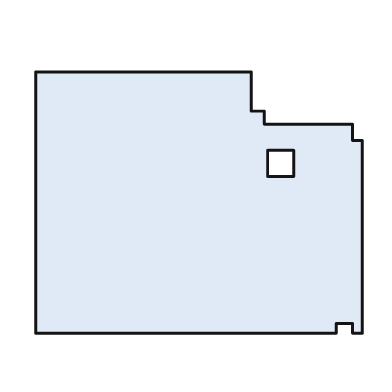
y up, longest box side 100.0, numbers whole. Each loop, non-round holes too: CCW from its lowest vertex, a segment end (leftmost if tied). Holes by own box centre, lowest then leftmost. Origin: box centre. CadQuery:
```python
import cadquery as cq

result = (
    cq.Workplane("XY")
    .moveTo(-50.0, -40.0)
    .lineTo(42.0, -40.0)
    .lineTo(42.0, -37.0)
    .lineTo(47.0, -37.0)
    .lineTo(47.0, -40.0)
    .lineTo(50.0, -40.0)
    .lineTo(50.0, 19.0)
    .lineTo(47.0, 19.0)
    .lineTo(47.0, 24.0)
    .lineTo(20.0, 24.0)
    .lineTo(20.0, 28.0)
    .lineTo(16.0, 28.0)
    .lineTo(16.0, 40.0)
    .lineTo(-50.0, 40.0)
    .close()
    .moveTo(21.0, 8.0)
    .lineTo(29.0, 8.0)
    .lineTo(29.0, 16.0)
    .lineTo(21.0, 16.0)
    .close()
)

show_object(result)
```